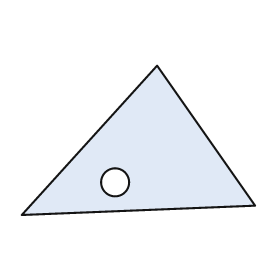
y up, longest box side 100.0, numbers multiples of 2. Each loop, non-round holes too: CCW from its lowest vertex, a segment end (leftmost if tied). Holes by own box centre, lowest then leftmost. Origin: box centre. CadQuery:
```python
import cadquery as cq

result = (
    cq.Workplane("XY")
    .moveTo(-50.0, -32.0)
    .lineTo(50.0, -28.0)
    .lineTo(8.0, 32.0)
    .close()
    .moveTo(-10.0, -18.0)
    .circle(6.0)
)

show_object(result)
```